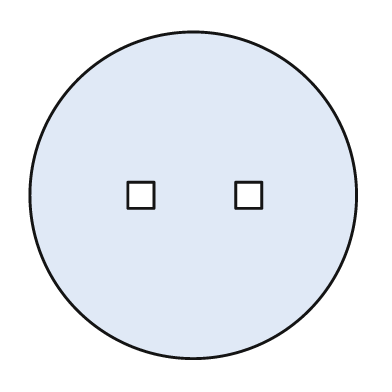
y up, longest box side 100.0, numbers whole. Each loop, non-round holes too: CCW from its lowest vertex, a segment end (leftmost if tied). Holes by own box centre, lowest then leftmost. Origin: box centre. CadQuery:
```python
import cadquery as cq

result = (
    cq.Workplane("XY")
    .moveTo(0.0, 0.0)
    .circle(50.0)
    .moveTo(-20.0, -4.0)
    .lineTo(-12.0, -4.0)
    .lineTo(-12.0, 4.0)
    .lineTo(-20.0, 4.0)
    .close()
    .moveTo(13.0, -4.0)
    .lineTo(21.0, -4.0)
    .lineTo(21.0, 4.0)
    .lineTo(13.0, 4.0)
    .close()
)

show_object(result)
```